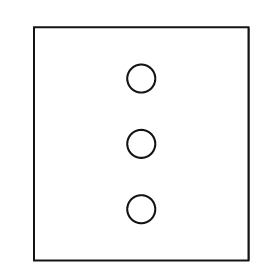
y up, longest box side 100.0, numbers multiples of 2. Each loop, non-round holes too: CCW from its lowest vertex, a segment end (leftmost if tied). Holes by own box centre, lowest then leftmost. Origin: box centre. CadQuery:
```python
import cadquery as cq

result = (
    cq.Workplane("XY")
    .moveTo(-46.0, -50.0)
    .lineTo(46.0, -50.0)
    .lineTo(46.0, 50.0)
    .lineTo(-46.0, 50.0)
    .close()
    .moveTo(0.0, -28.0)
    .circle(6.0)
    .moveTo(0.0, 0.0)
    .circle(6.0)
    .moveTo(0.0, 28.0)
    .circle(6.0)
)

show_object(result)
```